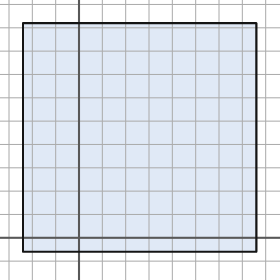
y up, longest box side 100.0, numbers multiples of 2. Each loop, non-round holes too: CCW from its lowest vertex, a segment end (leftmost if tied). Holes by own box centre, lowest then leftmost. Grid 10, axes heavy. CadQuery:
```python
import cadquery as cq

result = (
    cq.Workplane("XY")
    .moveTo(-24.0, -6.0)
    .lineTo(76.0, -6.0)
    .lineTo(76.0, 92.0)
    .lineTo(-24.0, 92.0)
    .close()
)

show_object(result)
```